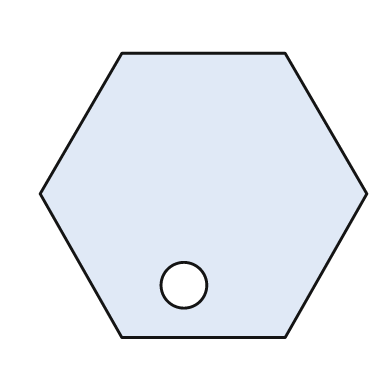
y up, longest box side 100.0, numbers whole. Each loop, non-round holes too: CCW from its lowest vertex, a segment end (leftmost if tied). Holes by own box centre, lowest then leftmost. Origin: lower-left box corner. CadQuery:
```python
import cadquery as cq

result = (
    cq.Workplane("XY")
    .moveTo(25.0, 0.0)
    .lineTo(75.0, 0.0)
    .lineTo(100.0, 44.0)
    .lineTo(75.0, 87.0)
    .lineTo(25.0, 87.0)
    .lineTo(0.0, 44.0)
    .close()
    .moveTo(44.0, 16.0)
    .circle(7.0)
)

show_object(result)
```